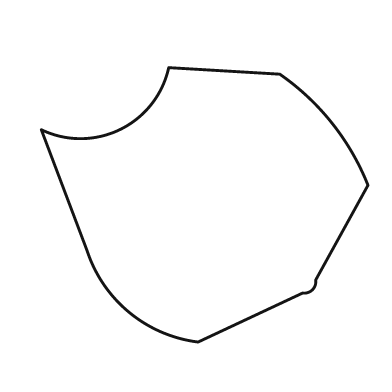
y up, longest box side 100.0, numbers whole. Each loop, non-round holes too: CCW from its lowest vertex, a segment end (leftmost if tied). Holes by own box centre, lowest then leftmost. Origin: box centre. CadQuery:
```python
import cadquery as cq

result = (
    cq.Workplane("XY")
    .moveTo(-2.0, -42.0)
    .lineTo(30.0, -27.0)
    .threePointArc((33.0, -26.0), (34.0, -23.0))
    .lineTo(50.0, 6.0)
    .threePointArc((39.0, 25.0), (23.0, 40.0))
    .lineTo(-11.0, 42.0)
    .threePointArc((-26.0, 23.0), (-50.0, 23.0))
    .lineTo(-36.0, -14.0)
    .threePointArc((-23.0, -33.0), (-2.0, -42.0))
    .close()
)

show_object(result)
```